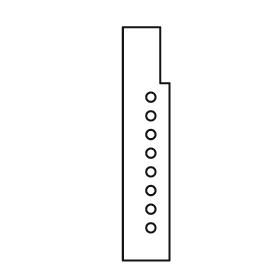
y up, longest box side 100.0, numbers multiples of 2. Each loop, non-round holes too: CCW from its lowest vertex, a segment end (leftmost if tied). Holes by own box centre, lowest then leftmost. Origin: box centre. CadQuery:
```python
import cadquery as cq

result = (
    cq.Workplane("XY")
    .moveTo(-10.0, -50.0)
    .lineTo(10.0, -50.0)
    .lineTo(10.0, 26.0)
    .lineTo(6.0, 26.0)
    .lineTo(6.0, 50.0)
    .lineTo(-10.0, 50.0)
    .close()
    .moveTo(2.0, -36.0)
    .circle(2.0)
    .moveTo(2.0, -28.0)
    .circle(2.0)
    .moveTo(2.0, -20.0)
    .circle(2.0)
    .moveTo(2.0, -12.0)
    .circle(2.0)
    .moveTo(2.0, -4.0)
    .circle(2.0)
    .moveTo(2.0, 4.0)
    .circle(2.0)
    .moveTo(2.0, 12.0)
    .circle(2.0)
    .moveTo(2.0, 20.0)
    .circle(2.0)
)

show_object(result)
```